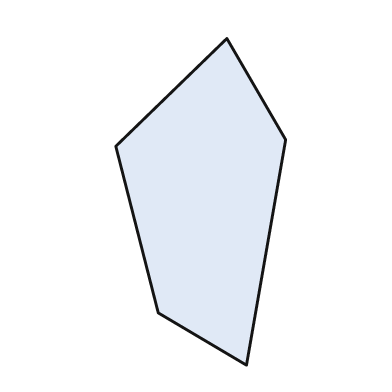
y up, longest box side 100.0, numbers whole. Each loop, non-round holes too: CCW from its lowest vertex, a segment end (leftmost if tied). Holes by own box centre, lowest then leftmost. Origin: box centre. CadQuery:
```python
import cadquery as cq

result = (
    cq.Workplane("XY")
    .moveTo(14.0, -50.0)
    .lineTo(26.0, 19.0)
    .lineTo(8.0, 50.0)
    .lineTo(-26.0, 17.0)
    .lineTo(-13.0, -34.0)
    .close()
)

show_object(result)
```